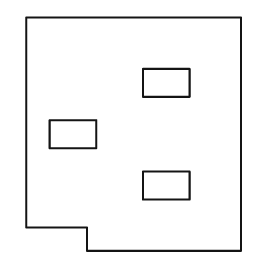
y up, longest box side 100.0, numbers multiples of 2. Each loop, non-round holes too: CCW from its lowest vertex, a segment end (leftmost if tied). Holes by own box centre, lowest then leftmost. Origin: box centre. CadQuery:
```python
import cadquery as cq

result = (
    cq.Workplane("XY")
    .moveTo(-20.0, -50.0)
    .lineTo(46.0, -50.0)
    .lineTo(46.0, 50.0)
    .lineTo(-46.0, 50.0)
    .lineTo(-46.0, -40.0)
    .lineTo(-20.0, -40.0)
    .close()
    .moveTo(4.0, -28.0)
    .lineTo(24.0, -28.0)
    .lineTo(24.0, -16.0)
    .lineTo(4.0, -16.0)
    .close()
    .moveTo(-36.0, -6.0)
    .lineTo(-16.0, -6.0)
    .lineTo(-16.0, 6.0)
    .lineTo(-36.0, 6.0)
    .close()
    .moveTo(4.0, 16.0)
    .lineTo(24.0, 16.0)
    .lineTo(24.0, 28.0)
    .lineTo(4.0, 28.0)
    .close()
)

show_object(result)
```